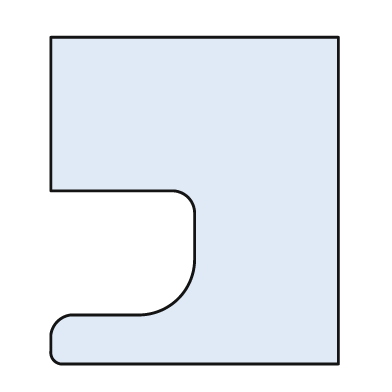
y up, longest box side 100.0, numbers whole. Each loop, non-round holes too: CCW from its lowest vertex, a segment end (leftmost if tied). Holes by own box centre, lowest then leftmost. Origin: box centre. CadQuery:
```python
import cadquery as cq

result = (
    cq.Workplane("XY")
    .moveTo(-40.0, -50.0)
    .lineTo(44.0, -50.0)
    .lineTo(44.0, 50.0)
    .lineTo(-44.0, 50.0)
    .lineTo(-44.0, 3.0)
    .lineTo(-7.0, 3.0)
    .threePointArc((-2.0, 1.0), (0.0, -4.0))
    .lineTo(0.0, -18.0)
    .threePointArc((-5.0, -30.0), (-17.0, -35.0))
    .lineTo(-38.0, -35.0)
    .threePointArc((-42.0, -37.0), (-44.0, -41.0))
    .lineTo(-44.0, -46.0)
    .threePointArc((-43.0, -49.0), (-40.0, -50.0))
    .close()
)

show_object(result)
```